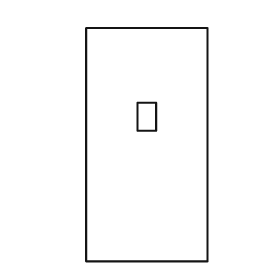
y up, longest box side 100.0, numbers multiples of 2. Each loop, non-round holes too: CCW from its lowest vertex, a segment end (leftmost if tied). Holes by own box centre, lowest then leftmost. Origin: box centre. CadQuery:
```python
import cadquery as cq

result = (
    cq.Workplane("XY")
    .moveTo(-26.0, -50.0)
    .lineTo(26.0, -50.0)
    .lineTo(26.0, 50.0)
    .lineTo(-26.0, 50.0)
    .close()
    .moveTo(-4.0, 6.0)
    .lineTo(4.0, 6.0)
    .lineTo(4.0, 18.0)
    .lineTo(-4.0, 18.0)
    .close()
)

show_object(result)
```